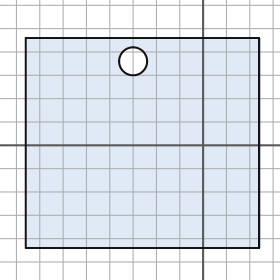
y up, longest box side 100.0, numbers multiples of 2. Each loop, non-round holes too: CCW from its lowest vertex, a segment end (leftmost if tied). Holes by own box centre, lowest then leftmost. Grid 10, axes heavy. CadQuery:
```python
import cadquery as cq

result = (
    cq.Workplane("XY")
    .moveTo(-76.0, -44.0)
    .lineTo(24.0, -44.0)
    .lineTo(24.0, 46.0)
    .lineTo(-76.0, 46.0)
    .close()
    .moveTo(-30.0, 36.0)
    .circle(6.0)
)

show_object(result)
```